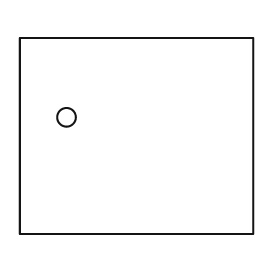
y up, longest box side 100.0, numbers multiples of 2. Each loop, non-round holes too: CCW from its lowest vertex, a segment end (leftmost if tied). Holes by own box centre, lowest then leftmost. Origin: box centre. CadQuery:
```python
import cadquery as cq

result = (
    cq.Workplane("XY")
    .moveTo(-50.0, -42.0)
    .lineTo(50.0, -42.0)
    .lineTo(50.0, 42.0)
    .lineTo(-50.0, 42.0)
    .close()
    .moveTo(-30.0, 8.0)
    .circle(4.0)
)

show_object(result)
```